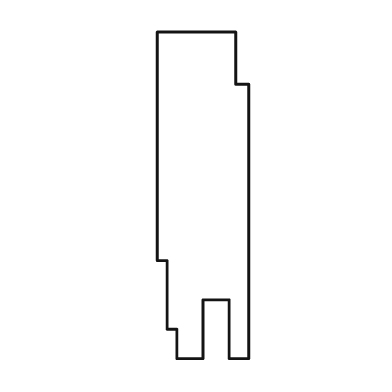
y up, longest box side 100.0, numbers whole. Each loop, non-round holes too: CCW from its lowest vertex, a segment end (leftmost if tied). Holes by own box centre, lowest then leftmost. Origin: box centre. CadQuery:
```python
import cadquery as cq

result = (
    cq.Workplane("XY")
    .moveTo(-8.0, -50.0)
    .lineTo(0.0, -50.0)
    .lineTo(0.0, -32.0)
    .lineTo(8.0, -32.0)
    .lineTo(8.0, -50.0)
    .lineTo(14.0, -50.0)
    .lineTo(14.0, 34.0)
    .lineTo(10.0, 34.0)
    .lineTo(10.0, 50.0)
    .lineTo(-14.0, 50.0)
    .lineTo(-14.0, -20.0)
    .lineTo(-11.0, -20.0)
    .lineTo(-11.0, -41.0)
    .lineTo(-8.0, -41.0)
    .close()
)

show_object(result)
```